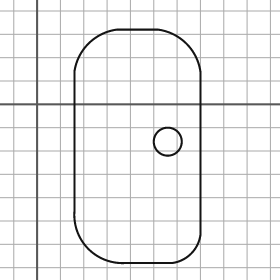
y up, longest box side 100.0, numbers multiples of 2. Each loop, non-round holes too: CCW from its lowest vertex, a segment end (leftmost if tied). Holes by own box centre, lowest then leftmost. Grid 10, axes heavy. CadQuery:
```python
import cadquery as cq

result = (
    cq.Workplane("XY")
    .moveTo(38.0, -68.0)
    .lineTo(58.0, -68.0)
    .threePointArc((66.0, -64.0), (70.0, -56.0))
    .lineTo(70.0, 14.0)
    .threePointArc((64.0, 26.0), (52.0, 32.0))
    .lineTo(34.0, 32.0)
    .threePointArc((22.0, 26.0), (16.0, 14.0))
    .lineTo(16.0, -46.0)
    .threePointArc((22.0, -62.0), (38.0, -68.0))
    .close()
    .moveTo(56.0, -16.0)
    .circle(6.0)
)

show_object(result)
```